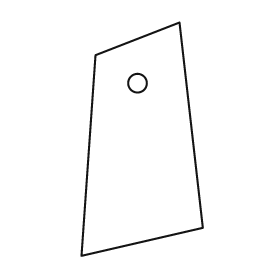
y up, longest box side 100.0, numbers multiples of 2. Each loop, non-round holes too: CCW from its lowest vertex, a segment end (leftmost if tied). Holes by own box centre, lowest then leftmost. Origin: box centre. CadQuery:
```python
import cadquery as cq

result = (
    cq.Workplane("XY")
    .moveTo(-26.0, -50.0)
    .lineTo(26.0, -38.0)
    .lineTo(16.0, 50.0)
    .lineTo(-20.0, 36.0)
    .close()
    .moveTo(-2.0, 24.0)
    .circle(4.0)
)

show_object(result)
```